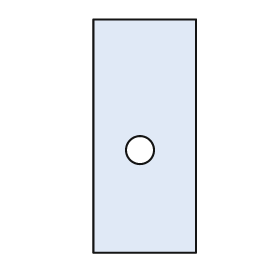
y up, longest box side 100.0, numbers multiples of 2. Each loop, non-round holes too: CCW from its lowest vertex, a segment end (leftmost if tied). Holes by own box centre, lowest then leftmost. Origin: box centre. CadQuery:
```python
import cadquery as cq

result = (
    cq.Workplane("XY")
    .moveTo(-22.0, -50.0)
    .lineTo(22.0, -50.0)
    .lineTo(22.0, 50.0)
    .lineTo(-22.0, 50.0)
    .close()
    .moveTo(-2.0, -6.0)
    .circle(6.0)
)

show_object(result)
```